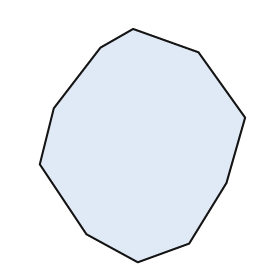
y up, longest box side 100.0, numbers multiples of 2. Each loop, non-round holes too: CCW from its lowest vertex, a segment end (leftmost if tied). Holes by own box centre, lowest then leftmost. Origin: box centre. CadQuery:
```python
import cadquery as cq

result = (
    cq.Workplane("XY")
    .moveTo(-2.0, -50.0)
    .lineTo(20.0, -42.0)
    .lineTo(36.0, -16.0)
    .lineTo(44.0, 12.0)
    .lineTo(24.0, 40.0)
    .lineTo(-4.0, 50.0)
    .lineTo(-18.0, 42.0)
    .lineTo(-38.0, 16.0)
    .lineTo(-44.0, -8.0)
    .lineTo(-24.0, -38.0)
    .close()
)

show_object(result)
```